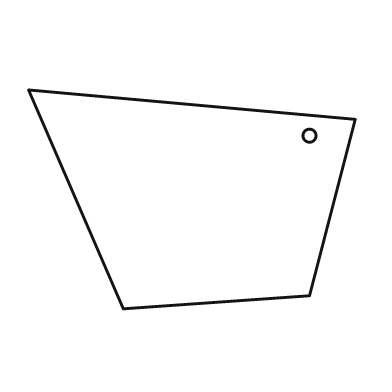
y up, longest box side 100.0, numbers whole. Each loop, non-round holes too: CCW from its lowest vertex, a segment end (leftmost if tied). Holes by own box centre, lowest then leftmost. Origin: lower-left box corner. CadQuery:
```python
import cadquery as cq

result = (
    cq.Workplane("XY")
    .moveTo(29.0, 0.0)
    .lineTo(86.0, 4.0)
    .lineTo(100.0, 58.0)
    .lineTo(0.0, 67.0)
    .close()
    .moveTo(86.0, 53.0)
    .circle(2.0)
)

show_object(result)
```